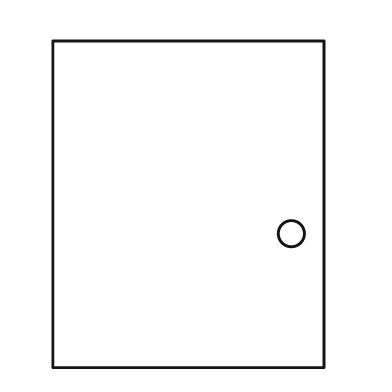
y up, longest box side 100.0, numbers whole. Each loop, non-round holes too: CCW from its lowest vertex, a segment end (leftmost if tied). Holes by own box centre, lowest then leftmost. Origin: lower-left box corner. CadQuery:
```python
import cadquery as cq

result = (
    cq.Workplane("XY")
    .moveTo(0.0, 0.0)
    .lineTo(83.0, 0.0)
    .lineTo(83.0, 100.0)
    .lineTo(0.0, 100.0)
    .close()
    .moveTo(73.0, 41.0)
    .circle(4.0)
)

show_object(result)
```